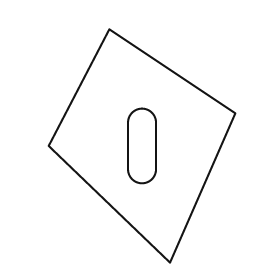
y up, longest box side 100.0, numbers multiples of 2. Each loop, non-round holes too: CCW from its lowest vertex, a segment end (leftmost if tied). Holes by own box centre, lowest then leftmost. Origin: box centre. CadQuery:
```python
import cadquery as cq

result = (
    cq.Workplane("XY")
    .moveTo(12.0, -50.0)
    .lineTo(40.0, 14.0)
    .lineTo(-14.0, 50.0)
    .lineTo(-40.0, 0.0)
    .close()
    .moveTo(-6.0, -10.0)
    .threePointArc((0.0, -16.0), (6.0, -10.0))
    .lineTo(6.0, 10.0)
    .threePointArc((0.0, 16.0), (-6.0, 10.0))
    .close()
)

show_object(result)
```